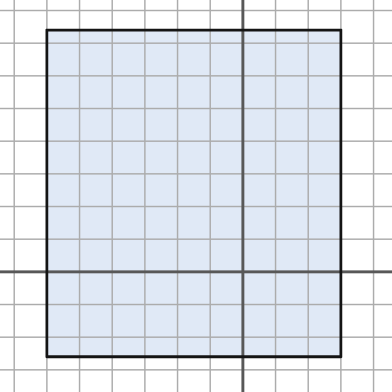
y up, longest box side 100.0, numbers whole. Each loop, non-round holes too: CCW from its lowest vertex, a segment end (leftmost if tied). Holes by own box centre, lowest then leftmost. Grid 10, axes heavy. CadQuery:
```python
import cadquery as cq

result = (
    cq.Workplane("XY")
    .moveTo(-60.0, -26.0)
    .lineTo(30.0, -26.0)
    .lineTo(30.0, 74.0)
    .lineTo(-60.0, 74.0)
    .close()
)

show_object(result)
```